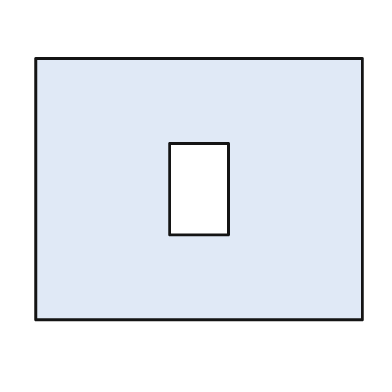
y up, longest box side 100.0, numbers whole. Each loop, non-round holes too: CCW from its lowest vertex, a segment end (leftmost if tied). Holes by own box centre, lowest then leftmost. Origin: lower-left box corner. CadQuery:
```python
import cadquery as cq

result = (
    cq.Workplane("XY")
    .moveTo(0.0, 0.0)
    .lineTo(100.0, 0.0)
    .lineTo(100.0, 80.0)
    .lineTo(0.0, 80.0)
    .close()
    .moveTo(41.0, 26.0)
    .lineTo(59.0, 26.0)
    .lineTo(59.0, 54.0)
    .lineTo(41.0, 54.0)
    .close()
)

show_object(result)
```